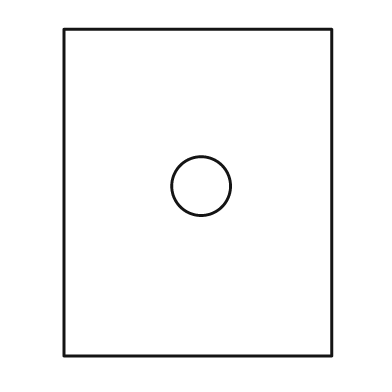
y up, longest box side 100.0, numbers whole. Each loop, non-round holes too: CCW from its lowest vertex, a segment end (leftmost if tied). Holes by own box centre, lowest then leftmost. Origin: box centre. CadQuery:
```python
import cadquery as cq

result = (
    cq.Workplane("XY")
    .moveTo(-41.0, -50.0)
    .lineTo(41.0, -50.0)
    .lineTo(41.0, 50.0)
    .lineTo(-41.0, 50.0)
    .close()
    .moveTo(1.0, 2.0)
    .circle(9.0)
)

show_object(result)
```